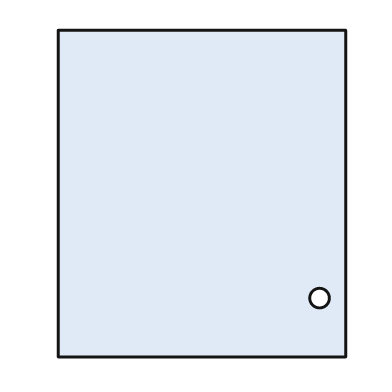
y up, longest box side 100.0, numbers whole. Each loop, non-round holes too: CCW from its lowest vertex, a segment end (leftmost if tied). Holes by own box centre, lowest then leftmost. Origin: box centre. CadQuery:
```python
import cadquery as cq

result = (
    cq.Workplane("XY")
    .moveTo(-44.0, -50.0)
    .lineTo(44.0, -50.0)
    .lineTo(44.0, 50.0)
    .lineTo(-44.0, 50.0)
    .close()
    .moveTo(36.0, -32.0)
    .circle(3.0)
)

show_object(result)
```